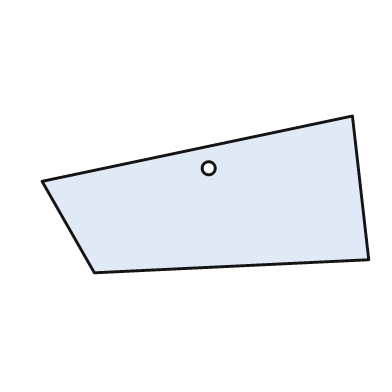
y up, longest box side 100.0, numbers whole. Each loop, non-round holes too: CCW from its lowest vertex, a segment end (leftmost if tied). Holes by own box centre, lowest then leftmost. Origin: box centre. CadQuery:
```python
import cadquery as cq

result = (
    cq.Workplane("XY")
    .moveTo(-34.0, -24.0)
    .lineTo(50.0, -20.0)
    .lineTo(45.0, 24.0)
    .lineTo(-50.0, 4.0)
    .close()
    .moveTo(1.0, 8.0)
    .circle(2.0)
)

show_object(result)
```